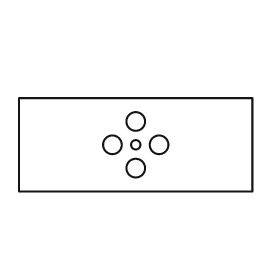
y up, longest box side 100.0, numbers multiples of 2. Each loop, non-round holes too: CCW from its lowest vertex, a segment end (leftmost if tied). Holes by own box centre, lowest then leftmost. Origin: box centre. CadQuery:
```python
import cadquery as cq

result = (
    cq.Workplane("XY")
    .moveTo(-50.0, -20.0)
    .lineTo(50.0, -20.0)
    .lineTo(50.0, 20.0)
    .lineTo(-50.0, 20.0)
    .close()
    .moveTo(0.0, -10.0)
    .circle(4.0)
    .moveTo(-10.0, 0.0)
    .circle(4.0)
    .moveTo(0.0, 0.0)
    .circle(2.0)
    .moveTo(10.0, 0.0)
    .circle(4.0)
    .moveTo(0.0, 10.0)
    .circle(4.0)
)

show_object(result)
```